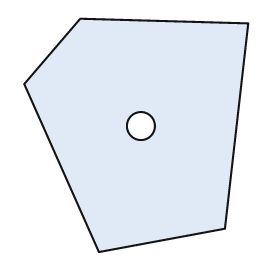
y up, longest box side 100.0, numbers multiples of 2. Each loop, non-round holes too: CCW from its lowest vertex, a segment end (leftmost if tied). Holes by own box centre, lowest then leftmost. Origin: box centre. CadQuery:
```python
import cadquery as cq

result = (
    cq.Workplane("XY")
    .moveTo(-16.0, -50.0)
    .lineTo(38.0, -40.0)
    .lineTo(48.0, 48.0)
    .lineTo(-24.0, 50.0)
    .lineTo(-48.0, 22.0)
    .close()
    .moveTo(2.0, 4.0)
    .circle(6.0)
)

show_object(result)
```